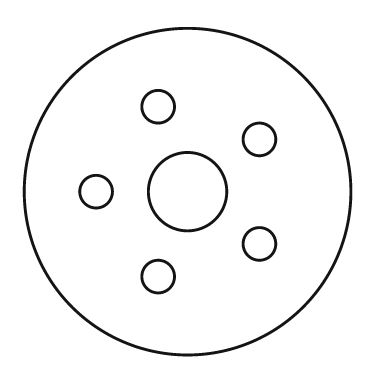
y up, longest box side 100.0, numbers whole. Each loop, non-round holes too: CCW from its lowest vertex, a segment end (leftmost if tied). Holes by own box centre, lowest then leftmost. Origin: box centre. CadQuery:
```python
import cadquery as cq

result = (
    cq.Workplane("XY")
    .moveTo(0.0, 0.0)
    .circle(50.0)
    .moveTo(-9.0, -26.0)
    .circle(5.0)
    .moveTo(22.0, -16.0)
    .circle(5.0)
    .moveTo(-28.0, 0.0)
    .circle(5.0)
    .moveTo(0.0, 0.0)
    .circle(12.0)
    .moveTo(22.0, 16.0)
    .circle(5.0)
    .moveTo(-9.0, 26.0)
    .circle(5.0)
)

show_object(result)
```